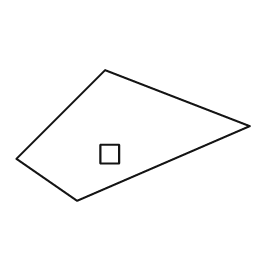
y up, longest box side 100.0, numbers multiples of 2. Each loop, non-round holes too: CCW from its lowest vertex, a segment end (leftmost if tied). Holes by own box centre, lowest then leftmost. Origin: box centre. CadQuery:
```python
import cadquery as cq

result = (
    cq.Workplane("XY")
    .moveTo(-24.0, -28.0)
    .lineTo(50.0, 4.0)
    .lineTo(-12.0, 28.0)
    .lineTo(-50.0, -10.0)
    .close()
    .moveTo(-14.0, -12.0)
    .lineTo(-6.0, -12.0)
    .lineTo(-6.0, -4.0)
    .lineTo(-14.0, -4.0)
    .close()
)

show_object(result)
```